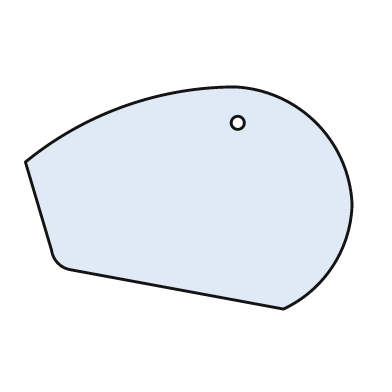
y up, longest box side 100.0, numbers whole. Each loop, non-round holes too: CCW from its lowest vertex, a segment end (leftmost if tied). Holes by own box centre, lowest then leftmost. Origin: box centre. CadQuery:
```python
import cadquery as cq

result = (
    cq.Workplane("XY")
    .moveTo(29.0, -34.0)
    .threePointArc((44.0, -21.0), (50.0, -2.0))
    .threePointArc((39.0, 23.0), (14.0, 34.0))
    .threePointArc((-20.0, 28.0), (-50.0, 11.0))
    .lineTo(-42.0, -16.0)
    .threePointArc((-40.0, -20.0), (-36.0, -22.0))
    .close()
    .moveTo(15.0, 23.0)
    .circle(2.0)
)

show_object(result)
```